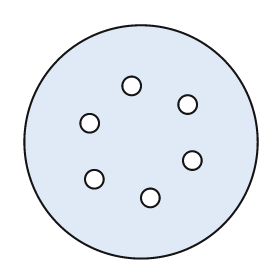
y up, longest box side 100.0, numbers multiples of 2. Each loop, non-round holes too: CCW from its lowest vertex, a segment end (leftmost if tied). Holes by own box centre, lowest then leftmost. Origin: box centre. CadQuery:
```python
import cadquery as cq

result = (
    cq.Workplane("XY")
    .moveTo(0.0, 0.0)
    .circle(50.0)
    .moveTo(4.0, -24.0)
    .circle(4.0)
    .moveTo(-20.0, -16.0)
    .circle(4.0)
    .moveTo(22.0, -8.0)
    .circle(4.0)
    .moveTo(-22.0, 8.0)
    .circle(4.0)
    .moveTo(20.0, 16.0)
    .circle(4.0)
    .moveTo(-4.0, 24.0)
    .circle(4.0)
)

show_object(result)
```